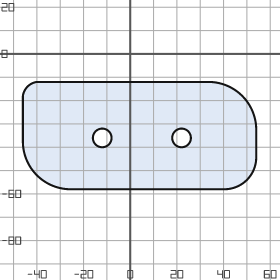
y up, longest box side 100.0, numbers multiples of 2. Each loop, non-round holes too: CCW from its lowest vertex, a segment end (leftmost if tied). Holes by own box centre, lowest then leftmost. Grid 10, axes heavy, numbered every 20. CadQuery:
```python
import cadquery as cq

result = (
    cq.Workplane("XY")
    .moveTo(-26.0, -58.0)
    .lineTo(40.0, -58.0)
    .threePointArc((50.0, -54.0), (54.0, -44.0))
    .lineTo(54.0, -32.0)
    .threePointArc((48.0, -18.0), (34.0, -12.0))
    .lineTo(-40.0, -12.0)
    .threePointArc((-44.0, -14.0), (-46.0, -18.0))
    .lineTo(-46.0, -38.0)
    .threePointArc((-40.0, -52.0), (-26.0, -58.0))
    .close()
    .moveTo(-12.0, -36.0)
    .circle(4.0)
    .moveTo(22.0, -36.0)
    .circle(4.0)
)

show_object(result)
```